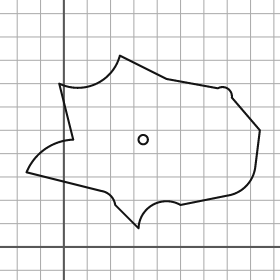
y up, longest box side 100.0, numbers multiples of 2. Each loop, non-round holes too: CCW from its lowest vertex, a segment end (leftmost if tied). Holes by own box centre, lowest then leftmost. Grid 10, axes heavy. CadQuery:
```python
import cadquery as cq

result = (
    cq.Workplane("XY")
    .moveTo(32.0, 8.0)
    .threePointArc((38.0, 18.0), (50.0, 18.0))
    .lineTo(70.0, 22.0)
    .threePointArc((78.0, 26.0), (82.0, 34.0))
    .lineTo(84.0, 50.0)
    .lineTo(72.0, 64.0)
    .threePointArc((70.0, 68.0), (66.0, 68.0))
    .lineTo(44.0, 72.0)
    .lineTo(24.0, 82.0)
    .threePointArc((14.0, 70.0), (-2.0, 70.0))
    .lineTo(4.0, 46.0)
    .threePointArc((-8.0, 42.0), (-16.0, 32.0))
    .lineTo(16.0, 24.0)
    .threePointArc((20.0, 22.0), (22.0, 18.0))
    .close()
    .moveTo(34.0, 46.0)
    .circle(2.0)
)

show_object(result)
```